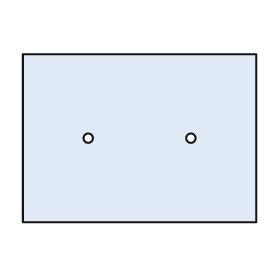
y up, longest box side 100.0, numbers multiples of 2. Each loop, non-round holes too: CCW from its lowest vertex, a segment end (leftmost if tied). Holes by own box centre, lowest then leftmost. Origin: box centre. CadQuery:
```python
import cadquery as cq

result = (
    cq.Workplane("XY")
    .moveTo(-50.0, -36.0)
    .lineTo(50.0, -36.0)
    .lineTo(50.0, 36.0)
    .lineTo(-50.0, 36.0)
    .close()
    .moveTo(-22.0, 0.0)
    .circle(2.0)
    .moveTo(22.0, 0.0)
    .circle(2.0)
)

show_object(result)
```